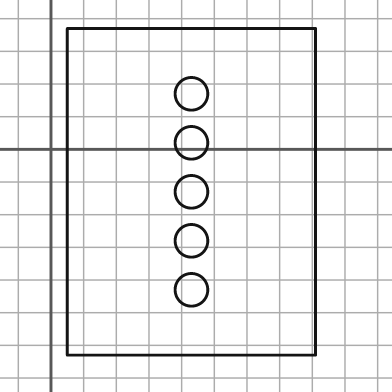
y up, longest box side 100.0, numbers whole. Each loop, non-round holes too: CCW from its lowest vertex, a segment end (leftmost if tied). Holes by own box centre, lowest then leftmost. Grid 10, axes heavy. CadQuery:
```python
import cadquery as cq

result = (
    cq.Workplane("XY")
    .moveTo(5.0, -63.0)
    .lineTo(81.0, -63.0)
    .lineTo(81.0, 37.0)
    .lineTo(5.0, 37.0)
    .close()
    .moveTo(43.0, -43.0)
    .circle(5.0)
    .moveTo(43.0, -28.0)
    .circle(5.0)
    .moveTo(43.0, -13.0)
    .circle(5.0)
    .moveTo(43.0, 2.0)
    .circle(5.0)
    .moveTo(43.0, 17.0)
    .circle(5.0)
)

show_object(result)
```